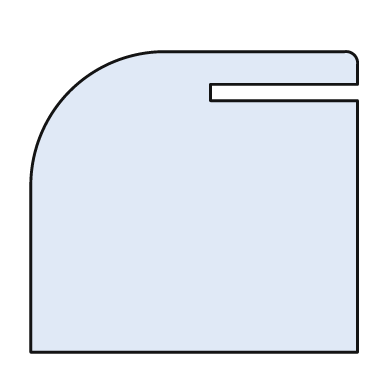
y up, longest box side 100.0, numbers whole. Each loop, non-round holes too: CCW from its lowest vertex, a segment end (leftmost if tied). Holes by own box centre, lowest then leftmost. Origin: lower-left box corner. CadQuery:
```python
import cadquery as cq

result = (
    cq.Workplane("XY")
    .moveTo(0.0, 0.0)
    .lineTo(100.0, 0.0)
    .lineTo(100.0, 77.0)
    .lineTo(55.0, 77.0)
    .lineTo(55.0, 82.0)
    .lineTo(100.0, 82.0)
    .lineTo(100.0, 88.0)
    .threePointArc((99.0, 91.0), (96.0, 92.0))
    .lineTo(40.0, 92.0)
    .threePointArc((12.0, 80.0), (0.0, 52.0))
    .close()
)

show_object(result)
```